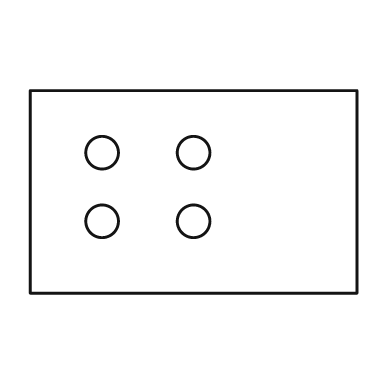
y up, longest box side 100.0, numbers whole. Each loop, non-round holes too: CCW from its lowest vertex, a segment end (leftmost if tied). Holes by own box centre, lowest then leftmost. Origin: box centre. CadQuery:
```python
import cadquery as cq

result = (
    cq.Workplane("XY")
    .moveTo(-50.0, -31.0)
    .lineTo(50.0, -31.0)
    .lineTo(50.0, 31.0)
    .lineTo(-50.0, 31.0)
    .close()
    .moveTo(-28.0, -9.0)
    .circle(5.0)
    .moveTo(0.0, -9.0)
    .circle(5.0)
    .moveTo(-28.0, 12.0)
    .circle(5.0)
    .moveTo(0.0, 12.0)
    .circle(5.0)
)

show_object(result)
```